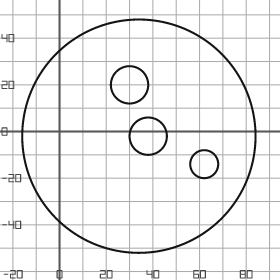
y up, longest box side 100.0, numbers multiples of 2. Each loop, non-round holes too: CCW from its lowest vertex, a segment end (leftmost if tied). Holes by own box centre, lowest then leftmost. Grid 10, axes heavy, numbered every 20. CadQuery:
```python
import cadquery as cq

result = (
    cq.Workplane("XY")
    .moveTo(34.0, -2.0)
    .circle(50.0)
    .moveTo(62.0, -14.0)
    .circle(6.0)
    .moveTo(38.0, -2.0)
    .circle(8.0)
    .moveTo(30.0, 20.0)
    .circle(8.0)
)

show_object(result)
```